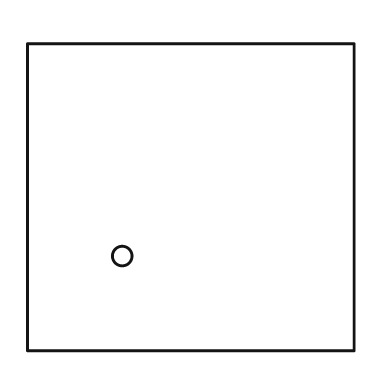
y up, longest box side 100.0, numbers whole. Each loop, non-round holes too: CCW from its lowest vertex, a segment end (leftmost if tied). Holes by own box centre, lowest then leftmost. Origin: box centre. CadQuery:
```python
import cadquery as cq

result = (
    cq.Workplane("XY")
    .moveTo(-50.0, -47.0)
    .lineTo(50.0, -47.0)
    .lineTo(50.0, 47.0)
    .lineTo(-50.0, 47.0)
    .close()
    .moveTo(-21.0, -18.0)
    .circle(3.0)
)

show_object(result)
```